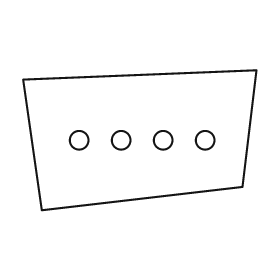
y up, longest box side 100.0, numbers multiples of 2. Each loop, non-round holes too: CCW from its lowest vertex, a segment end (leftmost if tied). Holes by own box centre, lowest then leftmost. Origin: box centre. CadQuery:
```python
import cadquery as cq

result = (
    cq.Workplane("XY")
    .moveTo(-42.0, -30.0)
    .lineTo(44.0, -20.0)
    .lineTo(50.0, 30.0)
    .lineTo(-50.0, 26.0)
    .close()
    .moveTo(-26.0, 0.0)
    .circle(4.0)
    .moveTo(-8.0, 0.0)
    .circle(4.0)
    .moveTo(10.0, 0.0)
    .circle(4.0)
    .moveTo(28.0, 0.0)
    .circle(4.0)
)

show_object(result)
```